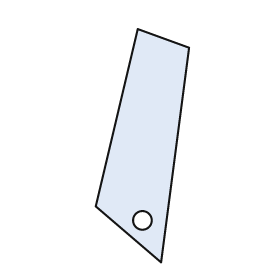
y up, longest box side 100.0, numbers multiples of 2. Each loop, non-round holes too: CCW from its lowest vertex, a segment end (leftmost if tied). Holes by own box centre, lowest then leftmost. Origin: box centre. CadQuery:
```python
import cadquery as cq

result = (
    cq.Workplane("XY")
    .moveTo(8.0, -50.0)
    .lineTo(20.0, 42.0)
    .lineTo(-2.0, 50.0)
    .lineTo(-20.0, -26.0)
    .close()
    .moveTo(0.0, -32.0)
    .circle(4.0)
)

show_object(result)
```